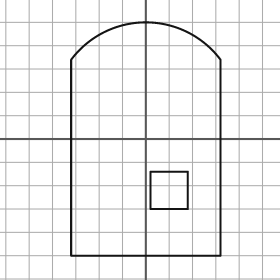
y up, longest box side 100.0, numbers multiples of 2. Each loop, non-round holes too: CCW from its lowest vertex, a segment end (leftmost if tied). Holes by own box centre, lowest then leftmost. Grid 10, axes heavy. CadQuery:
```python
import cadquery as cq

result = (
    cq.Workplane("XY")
    .moveTo(-32.0, -50.0)
    .lineTo(32.0, -50.0)
    .lineTo(32.0, 34.0)
    .threePointArc((0.0, 50.0), (-32.0, 34.0))
    .close()
    .moveTo(2.0, -30.0)
    .lineTo(18.0, -30.0)
    .lineTo(18.0, -14.0)
    .lineTo(2.0, -14.0)
    .close()
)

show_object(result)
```